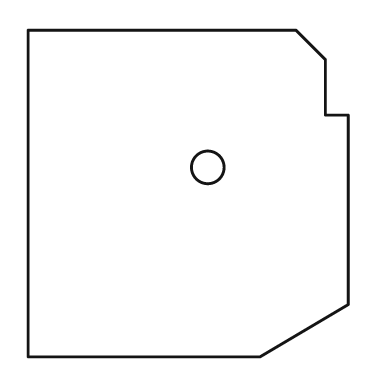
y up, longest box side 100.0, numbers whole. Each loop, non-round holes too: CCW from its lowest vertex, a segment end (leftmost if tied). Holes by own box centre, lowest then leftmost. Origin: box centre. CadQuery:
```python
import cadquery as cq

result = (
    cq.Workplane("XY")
    .moveTo(-49.0, -50.0)
    .lineTo(22.0, -50.0)
    .lineTo(49.0, -34.0)
    .lineTo(49.0, 24.0)
    .lineTo(42.0, 24.0)
    .lineTo(42.0, 41.0)
    .lineTo(33.0, 50.0)
    .lineTo(-49.0, 50.0)
    .close()
    .moveTo(6.0, 8.0)
    .circle(5.0)
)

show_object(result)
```